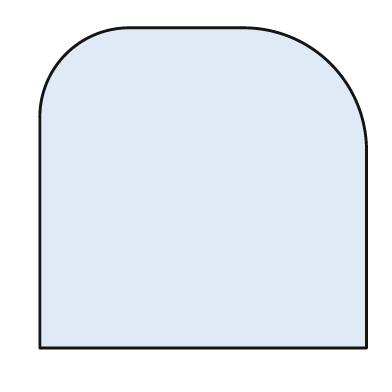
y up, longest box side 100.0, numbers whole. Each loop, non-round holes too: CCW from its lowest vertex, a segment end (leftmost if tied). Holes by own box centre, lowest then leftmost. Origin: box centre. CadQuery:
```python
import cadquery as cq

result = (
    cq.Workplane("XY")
    .moveTo(-50.0, -49.0)
    .lineTo(50.0, -49.0)
    .lineTo(50.0, 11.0)
    .threePointArc((39.0, 38.0), (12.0, 49.0))
    .lineTo(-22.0, 49.0)
    .threePointArc((-42.0, 41.0), (-50.0, 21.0))
    .close()
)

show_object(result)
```